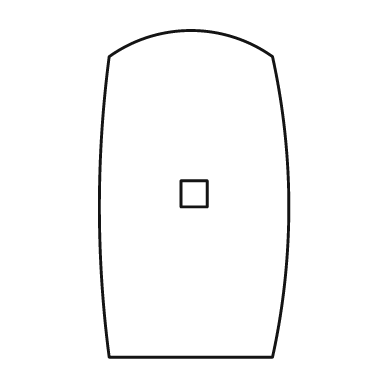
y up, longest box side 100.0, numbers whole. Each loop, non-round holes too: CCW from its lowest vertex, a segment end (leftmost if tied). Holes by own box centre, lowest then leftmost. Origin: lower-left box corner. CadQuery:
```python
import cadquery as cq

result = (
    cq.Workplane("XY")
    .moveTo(3.0, 0.0)
    .lineTo(53.0, 0.0)
    .threePointArc((58.0, 46.0), (53.0, 92.0))
    .threePointArc((28.0, 100.0), (3.0, 92.0))
    .threePointArc((0.0, 46.0), (3.0, 0.0))
    .close()
    .moveTo(25.0, 46.0)
    .lineTo(33.0, 46.0)
    .lineTo(33.0, 54.0)
    .lineTo(25.0, 54.0)
    .close()
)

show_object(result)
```